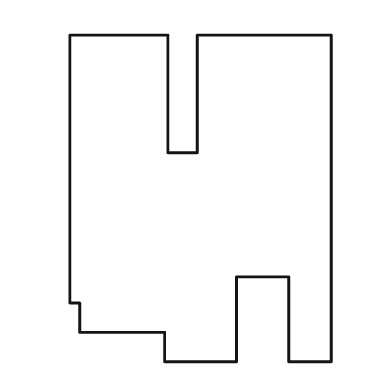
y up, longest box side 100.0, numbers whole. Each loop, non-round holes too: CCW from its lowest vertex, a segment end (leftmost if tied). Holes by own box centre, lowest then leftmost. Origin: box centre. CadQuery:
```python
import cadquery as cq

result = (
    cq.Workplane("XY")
    .moveTo(-11.0, -50.0)
    .lineTo(11.0, -50.0)
    .lineTo(11.0, -24.0)
    .lineTo(27.0, -24.0)
    .lineTo(27.0, -50.0)
    .lineTo(40.0, -50.0)
    .lineTo(40.0, 50.0)
    .lineTo(-1.0, 50.0)
    .lineTo(-1.0, 14.0)
    .lineTo(-10.0, 14.0)
    .lineTo(-10.0, 50.0)
    .lineTo(-40.0, 50.0)
    .lineTo(-40.0, -32.0)
    .lineTo(-37.0, -32.0)
    .lineTo(-37.0, -41.0)
    .lineTo(-11.0, -41.0)
    .close()
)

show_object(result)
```